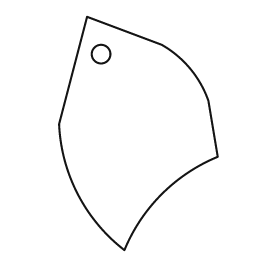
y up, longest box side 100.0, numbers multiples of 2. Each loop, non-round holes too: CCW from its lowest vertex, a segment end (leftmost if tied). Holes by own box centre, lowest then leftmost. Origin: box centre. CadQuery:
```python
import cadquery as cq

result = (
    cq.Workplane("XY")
    .moveTo(-6.0, -50.0)
    .threePointArc((10.0, -26.0), (34.0, -10.0))
    .lineTo(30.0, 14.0)
    .threePointArc((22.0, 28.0), (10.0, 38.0))
    .lineTo(-22.0, 50.0)
    .lineTo(-34.0, 4.0)
    .threePointArc((-26.0, -26.0), (-6.0, -50.0))
    .close()
    .moveTo(-16.0, 34.0)
    .circle(4.0)
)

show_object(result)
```